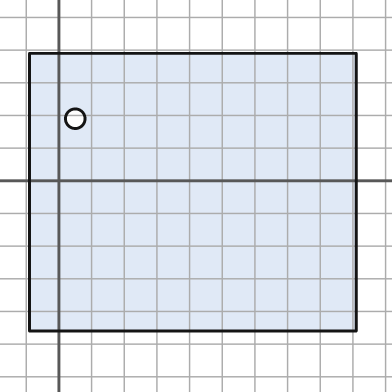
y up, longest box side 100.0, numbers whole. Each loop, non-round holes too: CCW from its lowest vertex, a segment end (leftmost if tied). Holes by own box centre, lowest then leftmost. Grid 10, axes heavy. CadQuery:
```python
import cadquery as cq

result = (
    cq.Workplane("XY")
    .moveTo(-9.0, -46.0)
    .lineTo(91.0, -46.0)
    .lineTo(91.0, 39.0)
    .lineTo(-9.0, 39.0)
    .close()
    .moveTo(5.0, 19.0)
    .circle(3.0)
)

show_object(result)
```